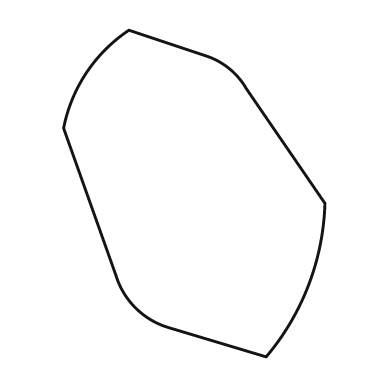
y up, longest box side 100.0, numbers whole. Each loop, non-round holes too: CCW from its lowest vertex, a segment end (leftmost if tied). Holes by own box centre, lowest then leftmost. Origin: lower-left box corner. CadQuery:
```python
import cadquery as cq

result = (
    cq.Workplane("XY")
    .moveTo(62.0, 0.0)
    .threePointArc((75.0, 22.0), (80.0, 47.0))
    .lineTo(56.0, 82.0)
    .threePointArc((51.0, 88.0), (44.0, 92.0))
    .lineTo(20.0, 100.0)
    .threePointArc((7.0, 87.0), (0.0, 70.0))
    .lineTo(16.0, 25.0)
    .threePointArc((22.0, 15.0), (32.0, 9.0))
    .close()
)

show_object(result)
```